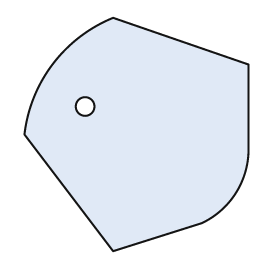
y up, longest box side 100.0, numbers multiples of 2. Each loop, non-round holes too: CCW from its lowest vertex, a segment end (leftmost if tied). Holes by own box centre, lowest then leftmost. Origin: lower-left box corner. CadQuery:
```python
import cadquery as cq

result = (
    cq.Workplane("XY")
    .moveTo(38.0, 0.0)
    .lineTo(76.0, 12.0)
    .threePointArc((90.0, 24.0), (96.0, 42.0))
    .lineTo(96.0, 80.0)
    .lineTo(38.0, 100.0)
    .threePointArc((12.0, 80.0), (0.0, 50.0))
    .close()
    .moveTo(26.0, 62.0)
    .circle(4.0)
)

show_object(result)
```